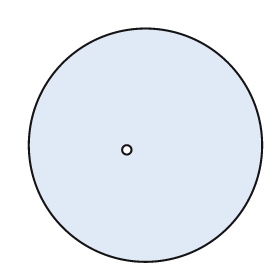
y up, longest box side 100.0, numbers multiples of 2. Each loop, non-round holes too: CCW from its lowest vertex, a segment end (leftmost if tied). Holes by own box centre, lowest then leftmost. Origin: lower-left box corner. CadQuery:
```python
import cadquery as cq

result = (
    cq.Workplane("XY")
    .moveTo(50.0, 50.0)
    .circle(50.0)
    .moveTo(42.0, 48.0)
    .circle(2.0)
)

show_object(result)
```